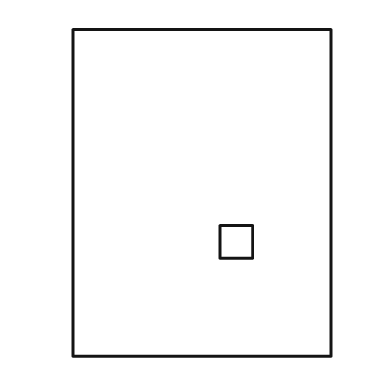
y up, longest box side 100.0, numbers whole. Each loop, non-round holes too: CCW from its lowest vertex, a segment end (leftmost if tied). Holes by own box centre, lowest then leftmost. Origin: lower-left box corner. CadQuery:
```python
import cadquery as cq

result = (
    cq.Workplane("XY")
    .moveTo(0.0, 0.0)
    .lineTo(79.0, 0.0)
    .lineTo(79.0, 100.0)
    .lineTo(0.0, 100.0)
    .close()
    .moveTo(45.0, 30.0)
    .lineTo(55.0, 30.0)
    .lineTo(55.0, 40.0)
    .lineTo(45.0, 40.0)
    .close()
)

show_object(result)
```